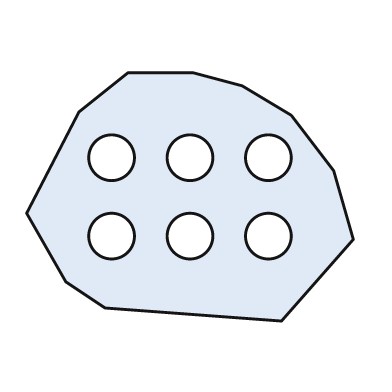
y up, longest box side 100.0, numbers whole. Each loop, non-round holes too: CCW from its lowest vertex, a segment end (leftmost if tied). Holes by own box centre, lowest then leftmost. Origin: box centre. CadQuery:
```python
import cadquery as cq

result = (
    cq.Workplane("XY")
    .moveTo(28.0, -38.0)
    .lineTo(50.0, -13.0)
    .lineTo(44.0, 8.0)
    .lineTo(31.0, 25.0)
    .lineTo(16.0, 34.0)
    .lineTo(1.0, 38.0)
    .lineTo(-19.0, 38.0)
    .lineTo(-34.0, 26.0)
    .lineTo(-50.0, -5.0)
    .lineTo(-38.0, -26.0)
    .lineTo(-26.0, -34.0)
    .close()
    .moveTo(-24.0, -12.0)
    .circle(7.0)
    .moveTo(0.0, -12.0)
    .circle(7.0)
    .moveTo(24.0, -12.0)
    .circle(7.0)
    .moveTo(-24.0, 12.0)
    .circle(7.0)
    .moveTo(0.0, 12.0)
    .circle(7.0)
    .moveTo(24.0, 12.0)
    .circle(7.0)
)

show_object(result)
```